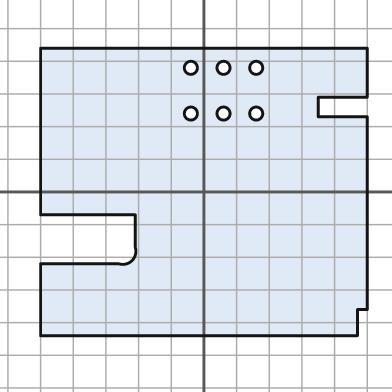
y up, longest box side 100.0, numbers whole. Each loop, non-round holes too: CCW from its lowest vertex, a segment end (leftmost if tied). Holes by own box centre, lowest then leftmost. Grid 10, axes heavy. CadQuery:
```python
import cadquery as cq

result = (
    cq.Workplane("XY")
    .moveTo(-50.0, -44.0)
    .lineTo(47.0, -44.0)
    .lineTo(47.0, -36.0)
    .lineTo(50.0, -36.0)
    .lineTo(50.0, 23.0)
    .lineTo(35.0, 23.0)
    .lineTo(35.0, 29.0)
    .lineTo(50.0, 29.0)
    .lineTo(50.0, 44.0)
    .lineTo(-50.0, 44.0)
    .lineTo(-50.0, -7.0)
    .lineTo(-21.0, -7.0)
    .lineTo(-21.0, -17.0)
    .threePointArc((-22.0, -21.0), (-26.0, -22.0))
    .lineTo(-50.0, -22.0)
    .close()
    .moveTo(-4.0, 24.0)
    .circle(2.0)
    .moveTo(6.0, 24.0)
    .circle(2.0)
    .moveTo(16.0, 24.0)
    .circle(2.0)
    .moveTo(-4.0, 38.0)
    .circle(2.0)
    .moveTo(6.0, 38.0)
    .circle(2.0)
    .moveTo(16.0, 38.0)
    .circle(2.0)
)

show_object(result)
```